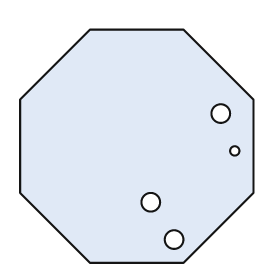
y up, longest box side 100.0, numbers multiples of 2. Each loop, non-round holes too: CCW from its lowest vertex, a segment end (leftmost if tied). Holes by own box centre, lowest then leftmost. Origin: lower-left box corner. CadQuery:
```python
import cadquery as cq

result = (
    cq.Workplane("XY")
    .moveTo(30.0, 0.0)
    .lineTo(70.0, 0.0)
    .lineTo(100.0, 30.0)
    .lineTo(100.0, 70.0)
    .lineTo(70.0, 100.0)
    .lineTo(30.0, 100.0)
    .lineTo(0.0, 70.0)
    .lineTo(0.0, 30.0)
    .close()
    .moveTo(66.0, 10.0)
    .circle(4.0)
    .moveTo(56.0, 26.0)
    .circle(4.0)
    .moveTo(92.0, 48.0)
    .circle(2.0)
    .moveTo(86.0, 64.0)
    .circle(4.0)
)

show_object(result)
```